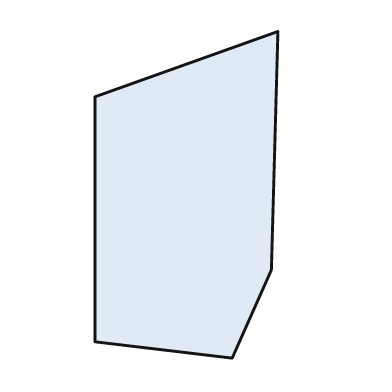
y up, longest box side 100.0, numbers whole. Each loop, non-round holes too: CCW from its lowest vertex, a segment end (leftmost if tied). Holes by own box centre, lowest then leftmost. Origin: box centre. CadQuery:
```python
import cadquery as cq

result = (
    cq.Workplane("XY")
    .moveTo(14.0, -50.0)
    .lineTo(26.0, -23.0)
    .lineTo(28.0, 50.0)
    .lineTo(-28.0, 30.0)
    .lineTo(-28.0, -45.0)
    .close()
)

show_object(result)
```